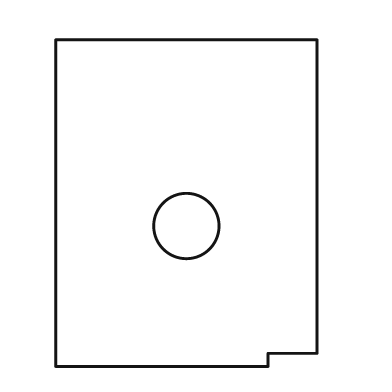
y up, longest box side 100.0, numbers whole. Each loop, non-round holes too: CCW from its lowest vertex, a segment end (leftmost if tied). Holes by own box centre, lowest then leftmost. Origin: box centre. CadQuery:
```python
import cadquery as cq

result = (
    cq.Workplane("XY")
    .moveTo(-40.0, -50.0)
    .lineTo(25.0, -50.0)
    .lineTo(25.0, -46.0)
    .lineTo(40.0, -46.0)
    .lineTo(40.0, 50.0)
    .lineTo(-40.0, 50.0)
    .close()
    .moveTo(0.0, -7.0)
    .circle(10.0)
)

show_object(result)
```